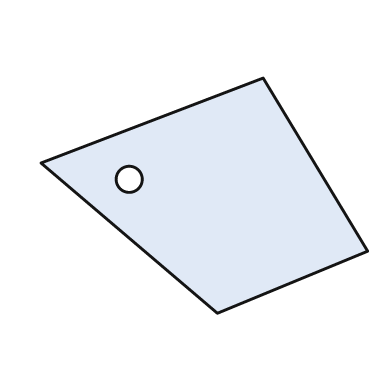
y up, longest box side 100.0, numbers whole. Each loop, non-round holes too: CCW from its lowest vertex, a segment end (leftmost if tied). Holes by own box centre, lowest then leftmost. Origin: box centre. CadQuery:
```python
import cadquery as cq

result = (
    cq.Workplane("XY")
    .moveTo(4.0, -36.0)
    .lineTo(50.0, -17.0)
    .lineTo(18.0, 36.0)
    .lineTo(-50.0, 10.0)
    .close()
    .moveTo(-23.0, 5.0)
    .circle(4.0)
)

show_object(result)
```